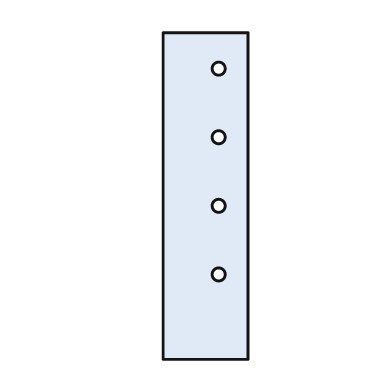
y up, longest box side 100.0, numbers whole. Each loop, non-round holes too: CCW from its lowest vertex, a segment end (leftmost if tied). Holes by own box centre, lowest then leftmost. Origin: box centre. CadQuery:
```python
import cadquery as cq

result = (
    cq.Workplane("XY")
    .moveTo(-13.0, -50.0)
    .lineTo(13.0, -50.0)
    .lineTo(13.0, 50.0)
    .lineTo(-13.0, 50.0)
    .close()
    .moveTo(4.0, -24.0)
    .circle(2.0)
    .moveTo(4.0, -3.0)
    .circle(2.0)
    .moveTo(4.0, 18.0)
    .circle(2.0)
    .moveTo(4.0, 39.0)
    .circle(2.0)
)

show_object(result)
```